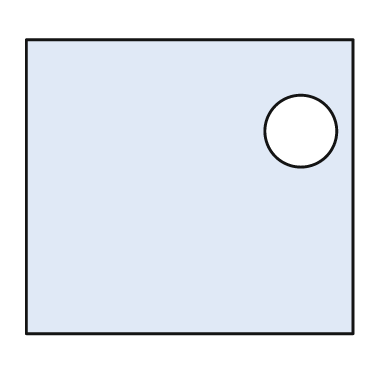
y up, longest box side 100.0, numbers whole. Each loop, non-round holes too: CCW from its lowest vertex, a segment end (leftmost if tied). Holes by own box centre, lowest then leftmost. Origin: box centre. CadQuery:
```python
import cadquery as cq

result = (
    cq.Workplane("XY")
    .moveTo(-50.0, -45.0)
    .lineTo(50.0, -45.0)
    .lineTo(50.0, 45.0)
    .lineTo(-50.0, 45.0)
    .close()
    .moveTo(34.0, 17.0)
    .circle(11.0)
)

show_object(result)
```